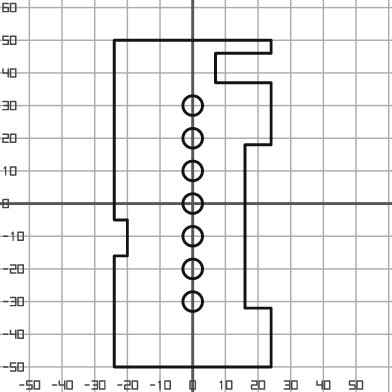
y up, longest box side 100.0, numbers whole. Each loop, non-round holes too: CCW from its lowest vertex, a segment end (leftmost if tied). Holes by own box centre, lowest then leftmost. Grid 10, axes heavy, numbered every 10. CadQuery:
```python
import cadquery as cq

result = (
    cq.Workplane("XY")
    .moveTo(-24.0, -50.0)
    .lineTo(24.0, -50.0)
    .lineTo(24.0, -32.0)
    .lineTo(16.0, -32.0)
    .lineTo(16.0, 18.0)
    .lineTo(24.0, 18.0)
    .lineTo(24.0, 37.0)
    .lineTo(7.0, 37.0)
    .lineTo(7.0, 46.0)
    .lineTo(24.0, 46.0)
    .lineTo(24.0, 50.0)
    .lineTo(-24.0, 50.0)
    .lineTo(-24.0, -5.0)
    .lineTo(-20.0, -5.0)
    .lineTo(-20.0, -16.0)
    .lineTo(-24.0, -16.0)
    .close()
    .moveTo(0.0, -30.0)
    .circle(3.0)
    .moveTo(0.0, -20.0)
    .circle(3.0)
    .moveTo(0.0, -10.0)
    .circle(3.0)
    .moveTo(0.0, 0.0)
    .circle(3.0)
    .moveTo(0.0, 10.0)
    .circle(3.0)
    .moveTo(0.0, 20.0)
    .circle(3.0)
    .moveTo(0.0, 30.0)
    .circle(3.0)
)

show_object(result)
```